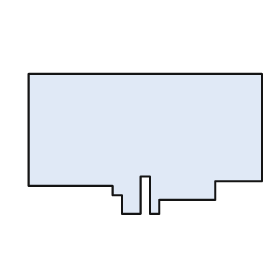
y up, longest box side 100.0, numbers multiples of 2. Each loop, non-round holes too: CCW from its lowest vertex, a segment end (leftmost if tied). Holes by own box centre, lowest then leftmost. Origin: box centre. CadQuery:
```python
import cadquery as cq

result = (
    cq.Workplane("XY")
    .moveTo(-10.0, -30.0)
    .lineTo(-2.0, -30.0)
    .lineTo(-2.0, -14.0)
    .lineTo(2.0, -14.0)
    .lineTo(2.0, -30.0)
    .lineTo(6.0, -30.0)
    .lineTo(6.0, -24.0)
    .lineTo(30.0, -24.0)
    .lineTo(30.0, -16.0)
    .lineTo(50.0, -16.0)
    .lineTo(50.0, 30.0)
    .lineTo(-50.0, 30.0)
    .lineTo(-50.0, -18.0)
    .lineTo(-14.0, -18.0)
    .lineTo(-14.0, -22.0)
    .lineTo(-10.0, -22.0)
    .close()
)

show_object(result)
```